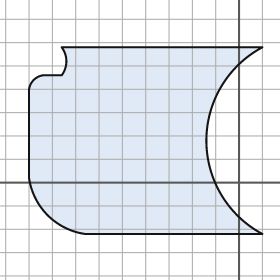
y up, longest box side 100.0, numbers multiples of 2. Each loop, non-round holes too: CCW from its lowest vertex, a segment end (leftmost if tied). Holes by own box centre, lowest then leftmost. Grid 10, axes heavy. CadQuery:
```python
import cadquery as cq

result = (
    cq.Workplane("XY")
    .moveTo(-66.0, -22.0)
    .lineTo(10.0, -22.0)
    .threePointArc((-14.0, 18.0), (10.0, 58.0))
    .lineTo(-76.0, 58.0)
    .threePointArc((-74.0, 52.0), (-76.0, 46.0))
    .lineTo(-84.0, 46.0)
    .threePointArc((-88.0, 44.0), (-90.0, 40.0))
    .lineTo(-90.0, 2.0)
    .threePointArc((-82.0, -14.0), (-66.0, -22.0))
    .close()
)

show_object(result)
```